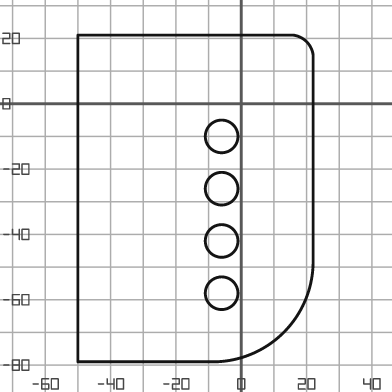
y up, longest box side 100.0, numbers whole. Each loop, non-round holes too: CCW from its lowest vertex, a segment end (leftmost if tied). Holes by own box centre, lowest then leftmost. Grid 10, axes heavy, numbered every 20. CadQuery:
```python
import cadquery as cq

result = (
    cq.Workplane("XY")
    .moveTo(-50.0, -79.0)
    .lineTo(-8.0, -79.0)
    .threePointArc((13.0, -70.0), (22.0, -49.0))
    .lineTo(22.0, 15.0)
    .threePointArc((20.0, 19.0), (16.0, 21.0))
    .lineTo(-50.0, 21.0)
    .close()
    .moveTo(-6.0, -58.0)
    .circle(5.0)
    .moveTo(-6.0, -42.0)
    .circle(5.0)
    .moveTo(-6.0, -26.0)
    .circle(5.0)
    .moveTo(-6.0, -10.0)
    .circle(5.0)
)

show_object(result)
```